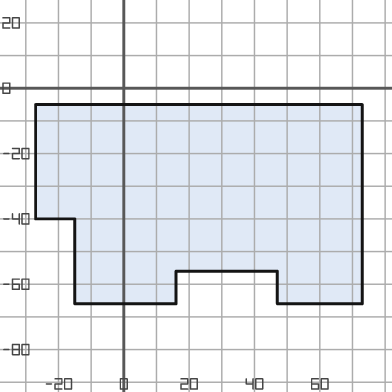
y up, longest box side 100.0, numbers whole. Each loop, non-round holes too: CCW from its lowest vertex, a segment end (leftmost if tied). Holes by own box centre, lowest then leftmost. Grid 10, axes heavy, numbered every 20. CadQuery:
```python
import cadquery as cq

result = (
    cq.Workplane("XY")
    .moveTo(-15.0, -66.0)
    .lineTo(16.0, -66.0)
    .lineTo(16.0, -56.0)
    .lineTo(47.0, -56.0)
    .lineTo(47.0, -66.0)
    .lineTo(73.0, -66.0)
    .lineTo(73.0, -5.0)
    .lineTo(-27.0, -5.0)
    .lineTo(-27.0, -40.0)
    .lineTo(-15.0, -40.0)
    .close()
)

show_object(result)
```